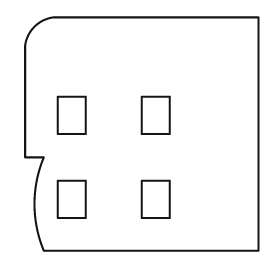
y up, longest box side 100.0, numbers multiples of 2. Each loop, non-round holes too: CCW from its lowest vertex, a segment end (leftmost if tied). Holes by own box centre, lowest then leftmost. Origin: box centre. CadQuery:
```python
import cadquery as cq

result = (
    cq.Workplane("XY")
    .moveTo(-42.0, -50.0)
    .lineTo(50.0, -50.0)
    .lineTo(50.0, 50.0)
    .lineTo(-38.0, 50.0)
    .threePointArc((-46.0, 46.0), (-50.0, 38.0))
    .lineTo(-50.0, -10.0)
    .lineTo(-42.0, -10.0)
    .threePointArc((-46.0, -30.0), (-42.0, -50.0))
    .close()
    .moveTo(-36.0, -36.0)
    .lineTo(-24.0, -36.0)
    .lineTo(-24.0, -20.0)
    .lineTo(-36.0, -20.0)
    .close()
    .moveTo(0.0, -36.0)
    .lineTo(12.0, -36.0)
    .lineTo(12.0, -20.0)
    .lineTo(0.0, -20.0)
    .close()
    .moveTo(-36.0, 0.0)
    .lineTo(-24.0, 0.0)
    .lineTo(-24.0, 16.0)
    .lineTo(-36.0, 16.0)
    .close()
    .moveTo(0.0, 0.0)
    .lineTo(12.0, 0.0)
    .lineTo(12.0, 16.0)
    .lineTo(0.0, 16.0)
    .close()
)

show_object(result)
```